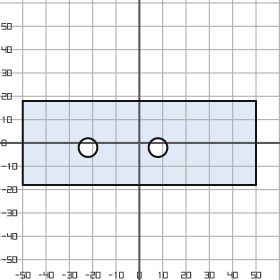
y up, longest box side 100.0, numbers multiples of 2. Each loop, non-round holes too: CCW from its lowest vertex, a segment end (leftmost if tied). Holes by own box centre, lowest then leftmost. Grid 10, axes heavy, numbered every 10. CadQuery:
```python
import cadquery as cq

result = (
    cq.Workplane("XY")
    .moveTo(-50.0, -18.0)
    .lineTo(50.0, -18.0)
    .lineTo(50.0, 18.0)
    .lineTo(-50.0, 18.0)
    .close()
    .moveTo(-22.0, -2.0)
    .circle(4.0)
    .moveTo(8.0, -2.0)
    .circle(4.0)
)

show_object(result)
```